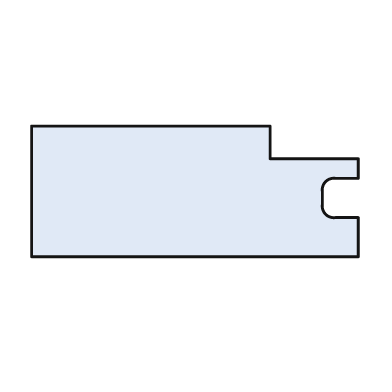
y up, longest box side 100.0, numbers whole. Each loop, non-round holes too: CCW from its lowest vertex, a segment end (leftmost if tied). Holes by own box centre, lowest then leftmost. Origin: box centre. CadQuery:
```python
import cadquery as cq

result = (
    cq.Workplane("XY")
    .moveTo(-50.0, -20.0)
    .lineTo(50.0, -20.0)
    .lineTo(50.0, -8.0)
    .lineTo(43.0, -8.0)
    .threePointArc((40.0, -7.0), (39.0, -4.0))
    .lineTo(39.0, 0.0)
    .threePointArc((40.0, 3.0), (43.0, 4.0))
    .lineTo(50.0, 4.0)
    .lineTo(50.0, 10.0)
    .lineTo(23.0, 10.0)
    .lineTo(23.0, 20.0)
    .lineTo(-50.0, 20.0)
    .close()
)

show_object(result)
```